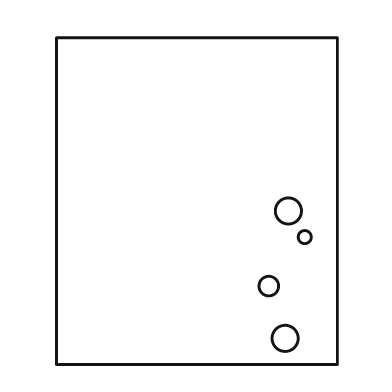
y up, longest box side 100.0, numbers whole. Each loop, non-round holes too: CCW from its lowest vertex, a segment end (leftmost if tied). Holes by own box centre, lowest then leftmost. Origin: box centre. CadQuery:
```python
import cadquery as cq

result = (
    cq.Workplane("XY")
    .moveTo(-43.0, -50.0)
    .lineTo(43.0, -50.0)
    .lineTo(43.0, 50.0)
    .lineTo(-43.0, 50.0)
    .close()
    .moveTo(27.0, -42.0)
    .circle(4.0)
    .moveTo(22.0, -26.0)
    .circle(3.0)
    .moveTo(33.0, -11.0)
    .circle(2.0)
    .moveTo(28.0, -3.0)
    .circle(4.0)
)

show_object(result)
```